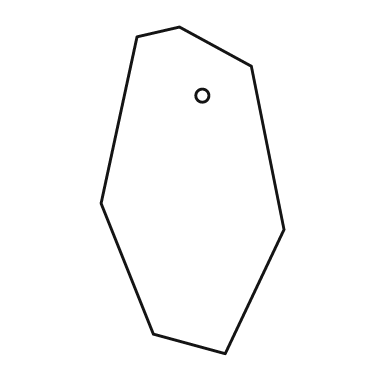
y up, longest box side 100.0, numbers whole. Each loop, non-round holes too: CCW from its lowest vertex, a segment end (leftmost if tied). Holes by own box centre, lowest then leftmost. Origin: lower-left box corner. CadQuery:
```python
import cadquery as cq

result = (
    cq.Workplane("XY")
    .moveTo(38.0, 0.0)
    .lineTo(56.0, 38.0)
    .lineTo(46.0, 88.0)
    .lineTo(24.0, 100.0)
    .lineTo(11.0, 97.0)
    .lineTo(0.0, 46.0)
    .lineTo(16.0, 6.0)
    .close()
    .moveTo(31.0, 79.0)
    .circle(2.0)
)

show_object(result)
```